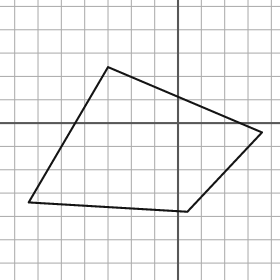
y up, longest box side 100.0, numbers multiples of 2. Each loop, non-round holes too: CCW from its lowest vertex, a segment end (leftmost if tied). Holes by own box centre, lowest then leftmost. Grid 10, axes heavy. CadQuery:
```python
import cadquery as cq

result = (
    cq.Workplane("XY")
    .moveTo(4.0, -38.0)
    .lineTo(36.0, -4.0)
    .lineTo(-30.0, 24.0)
    .lineTo(-64.0, -34.0)
    .close()
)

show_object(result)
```